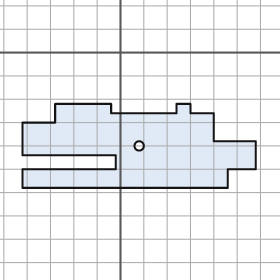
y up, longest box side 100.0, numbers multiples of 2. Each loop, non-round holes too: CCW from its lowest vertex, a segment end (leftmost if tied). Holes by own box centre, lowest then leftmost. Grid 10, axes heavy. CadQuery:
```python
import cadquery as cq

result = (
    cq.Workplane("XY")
    .moveTo(-42.0, -58.0)
    .lineTo(46.0, -58.0)
    .lineTo(46.0, -50.0)
    .lineTo(58.0, -50.0)
    .lineTo(58.0, -38.0)
    .lineTo(40.0, -38.0)
    .lineTo(40.0, -26.0)
    .lineTo(30.0, -26.0)
    .lineTo(30.0, -22.0)
    .lineTo(24.0, -22.0)
    .lineTo(24.0, -26.0)
    .lineTo(-4.0, -26.0)
    .lineTo(-4.0, -22.0)
    .lineTo(-28.0, -22.0)
    .lineTo(-28.0, -30.0)
    .lineTo(-42.0, -30.0)
    .lineTo(-42.0, -44.0)
    .lineTo(-2.0, -44.0)
    .lineTo(-2.0, -50.0)
    .lineTo(-42.0, -50.0)
    .close()
    .moveTo(8.0, -40.0)
    .circle(2.0)
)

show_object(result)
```